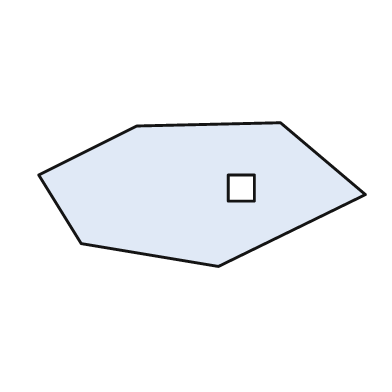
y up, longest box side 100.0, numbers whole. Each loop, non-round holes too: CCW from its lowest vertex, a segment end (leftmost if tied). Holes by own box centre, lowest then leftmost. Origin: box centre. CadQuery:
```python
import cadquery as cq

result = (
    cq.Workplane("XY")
    .moveTo(5.0, -22.0)
    .lineTo(50.0, 0.0)
    .lineTo(24.0, 22.0)
    .lineTo(-20.0, 21.0)
    .lineTo(-50.0, 6.0)
    .lineTo(-37.0, -15.0)
    .close()
    .moveTo(8.0, -2.0)
    .lineTo(16.0, -2.0)
    .lineTo(16.0, 6.0)
    .lineTo(8.0, 6.0)
    .close()
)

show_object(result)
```